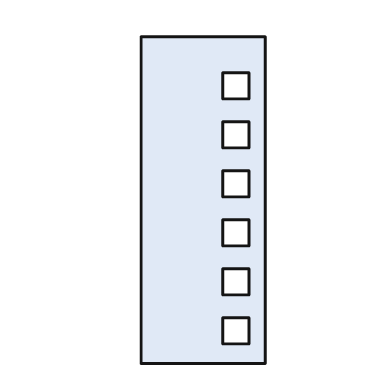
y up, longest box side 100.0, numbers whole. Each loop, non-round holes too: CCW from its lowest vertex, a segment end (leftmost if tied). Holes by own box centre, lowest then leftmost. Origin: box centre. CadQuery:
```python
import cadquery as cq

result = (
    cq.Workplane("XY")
    .moveTo(-19.0, -50.0)
    .lineTo(19.0, -50.0)
    .lineTo(19.0, 50.0)
    .lineTo(-19.0, 50.0)
    .close()
    .moveTo(6.0, -44.0)
    .lineTo(14.0, -44.0)
    .lineTo(14.0, -36.0)
    .lineTo(6.0, -36.0)
    .close()
    .moveTo(6.0, -29.0)
    .lineTo(14.0, -29.0)
    .lineTo(14.0, -21.0)
    .lineTo(6.0, -21.0)
    .close()
    .moveTo(6.0, -14.0)
    .lineTo(14.0, -14.0)
    .lineTo(14.0, -6.0)
    .lineTo(6.0, -6.0)
    .close()
    .moveTo(6.0, 1.0)
    .lineTo(14.0, 1.0)
    .lineTo(14.0, 9.0)
    .lineTo(6.0, 9.0)
    .close()
    .moveTo(6.0, 16.0)
    .lineTo(14.0, 16.0)
    .lineTo(14.0, 24.0)
    .lineTo(6.0, 24.0)
    .close()
    .moveTo(6.0, 31.0)
    .lineTo(14.0, 31.0)
    .lineTo(14.0, 39.0)
    .lineTo(6.0, 39.0)
    .close()
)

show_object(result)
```